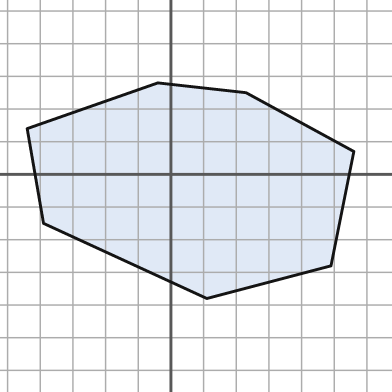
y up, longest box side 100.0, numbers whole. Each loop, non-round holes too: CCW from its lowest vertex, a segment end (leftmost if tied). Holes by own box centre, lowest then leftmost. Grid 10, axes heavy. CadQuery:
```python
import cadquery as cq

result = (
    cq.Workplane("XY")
    .moveTo(11.0, -38.0)
    .lineTo(49.0, -28.0)
    .lineTo(56.0, 7.0)
    .lineTo(23.0, 25.0)
    .lineTo(-4.0, 28.0)
    .lineTo(-44.0, 14.0)
    .lineTo(-39.0, -15.0)
    .close()
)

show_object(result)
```